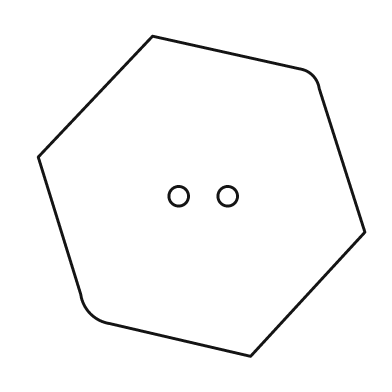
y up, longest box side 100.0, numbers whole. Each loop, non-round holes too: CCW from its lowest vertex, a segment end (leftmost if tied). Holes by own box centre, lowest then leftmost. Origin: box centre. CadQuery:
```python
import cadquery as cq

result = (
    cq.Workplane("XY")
    .moveTo(15.0, -49.0)
    .lineTo(50.0, -11.0)
    .lineTo(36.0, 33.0)
    .threePointArc((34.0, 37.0), (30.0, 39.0))
    .lineTo(-15.0, 49.0)
    .lineTo(-50.0, 12.0)
    .lineTo(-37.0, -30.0)
    .threePointArc((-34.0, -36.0), (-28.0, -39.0))
    .close()
    .moveTo(-7.0, 0.0)
    .circle(3.0)
    .moveTo(8.0, 0.0)
    .circle(3.0)
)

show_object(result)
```